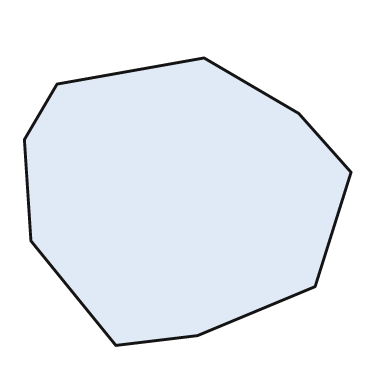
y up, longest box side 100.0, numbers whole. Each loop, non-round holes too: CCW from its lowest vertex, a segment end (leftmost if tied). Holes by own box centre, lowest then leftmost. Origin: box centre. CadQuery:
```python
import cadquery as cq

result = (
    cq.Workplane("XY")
    .moveTo(-22.0, -44.0)
    .lineTo(3.0, -41.0)
    .lineTo(39.0, -26.0)
    .lineTo(50.0, 9.0)
    .lineTo(34.0, 27.0)
    .lineTo(5.0, 44.0)
    .lineTo(-40.0, 36.0)
    .lineTo(-50.0, 19.0)
    .lineTo(-48.0, -12.0)
    .close()
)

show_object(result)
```